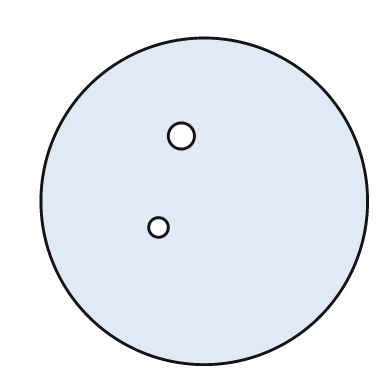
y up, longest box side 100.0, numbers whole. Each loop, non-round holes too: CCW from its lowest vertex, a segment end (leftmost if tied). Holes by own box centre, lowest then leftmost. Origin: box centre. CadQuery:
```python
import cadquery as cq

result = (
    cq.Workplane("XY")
    .moveTo(0.0, 0.0)
    .circle(50.0)
    .moveTo(-14.0, -8.0)
    .circle(3.0)
    .moveTo(-7.0, 20.0)
    .circle(4.0)
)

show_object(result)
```